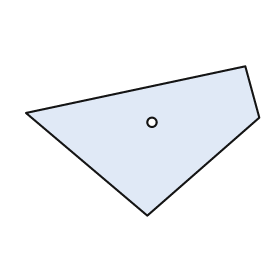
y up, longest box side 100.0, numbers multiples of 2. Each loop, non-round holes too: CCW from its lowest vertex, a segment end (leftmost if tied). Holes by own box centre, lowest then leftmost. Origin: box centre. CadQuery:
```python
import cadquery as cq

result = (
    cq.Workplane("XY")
    .moveTo(2.0, -32.0)
    .lineTo(50.0, 10.0)
    .lineTo(44.0, 32.0)
    .lineTo(-50.0, 12.0)
    .close()
    .moveTo(4.0, 8.0)
    .circle(2.0)
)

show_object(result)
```